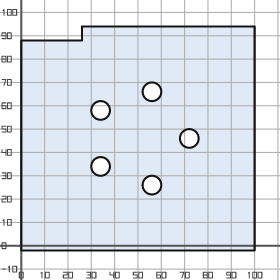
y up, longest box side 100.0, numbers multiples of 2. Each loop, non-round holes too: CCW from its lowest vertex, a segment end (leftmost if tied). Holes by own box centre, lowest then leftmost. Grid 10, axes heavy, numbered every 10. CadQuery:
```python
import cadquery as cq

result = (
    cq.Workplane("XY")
    .moveTo(0.0, -2.0)
    .lineTo(100.0, -2.0)
    .lineTo(100.0, 94.0)
    .lineTo(26.0, 94.0)
    .lineTo(26.0, 88.0)
    .lineTo(0.0, 88.0)
    .close()
    .moveTo(56.0, 26.0)
    .circle(4.0)
    .moveTo(34.0, 34.0)
    .circle(4.0)
    .moveTo(72.0, 46.0)
    .circle(4.0)
    .moveTo(34.0, 58.0)
    .circle(4.0)
    .moveTo(56.0, 66.0)
    .circle(4.0)
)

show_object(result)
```